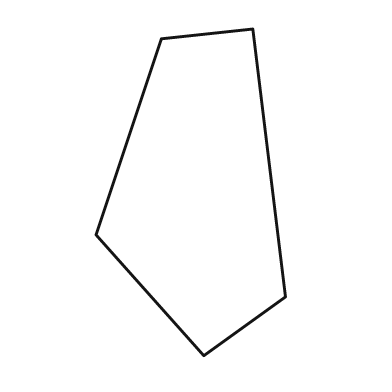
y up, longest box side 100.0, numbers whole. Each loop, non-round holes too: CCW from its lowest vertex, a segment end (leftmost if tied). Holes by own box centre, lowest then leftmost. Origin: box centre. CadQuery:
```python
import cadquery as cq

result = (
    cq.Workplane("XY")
    .moveTo(4.0, -50.0)
    .lineTo(29.0, -32.0)
    .lineTo(19.0, 50.0)
    .lineTo(-9.0, 47.0)
    .lineTo(-29.0, -13.0)
    .close()
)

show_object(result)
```